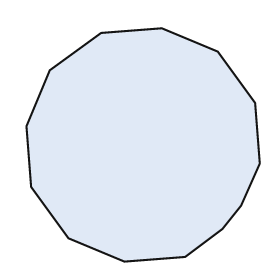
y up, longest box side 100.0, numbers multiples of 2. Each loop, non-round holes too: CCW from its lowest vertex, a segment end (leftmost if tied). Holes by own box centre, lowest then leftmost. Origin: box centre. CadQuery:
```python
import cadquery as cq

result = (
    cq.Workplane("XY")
    .moveTo(-8.0, -50.0)
    .lineTo(18.0, -48.0)
    .lineTo(34.0, -36.0)
    .lineTo(42.0, -26.0)
    .lineTo(50.0, -8.0)
    .lineTo(48.0, 18.0)
    .lineTo(32.0, 40.0)
    .lineTo(8.0, 50.0)
    .lineTo(-18.0, 48.0)
    .lineTo(-40.0, 32.0)
    .lineTo(-50.0, 8.0)
    .lineTo(-48.0, -18.0)
    .lineTo(-32.0, -40.0)
    .close()
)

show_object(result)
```